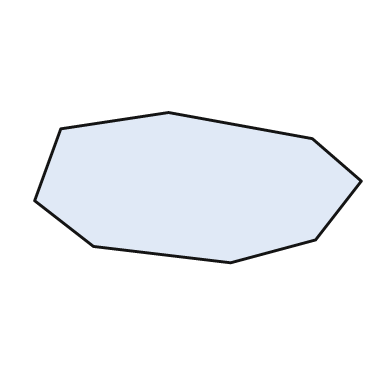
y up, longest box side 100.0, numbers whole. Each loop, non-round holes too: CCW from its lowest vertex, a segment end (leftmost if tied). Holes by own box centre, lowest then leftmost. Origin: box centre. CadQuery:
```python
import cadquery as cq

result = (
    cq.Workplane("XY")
    .moveTo(10.0, -23.0)
    .lineTo(36.0, -16.0)
    .lineTo(50.0, 2.0)
    .lineTo(35.0, 15.0)
    .lineTo(-9.0, 23.0)
    .lineTo(-42.0, 18.0)
    .lineTo(-50.0, -4.0)
    .lineTo(-32.0, -18.0)
    .close()
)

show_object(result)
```